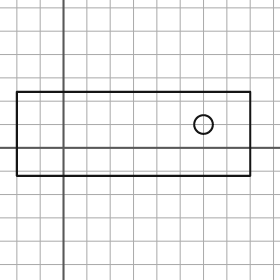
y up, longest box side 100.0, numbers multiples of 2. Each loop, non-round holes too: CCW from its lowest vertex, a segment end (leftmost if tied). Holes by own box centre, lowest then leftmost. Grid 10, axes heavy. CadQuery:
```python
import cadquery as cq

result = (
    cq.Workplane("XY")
    .moveTo(-20.0, -12.0)
    .lineTo(80.0, -12.0)
    .lineTo(80.0, 24.0)
    .lineTo(-20.0, 24.0)
    .close()
    .moveTo(60.0, 10.0)
    .circle(4.0)
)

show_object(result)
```